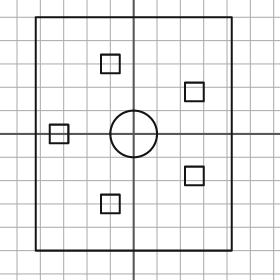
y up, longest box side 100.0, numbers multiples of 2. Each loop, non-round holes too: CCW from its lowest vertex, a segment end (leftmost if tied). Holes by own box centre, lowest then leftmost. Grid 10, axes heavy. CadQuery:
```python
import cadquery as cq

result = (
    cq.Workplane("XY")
    .moveTo(-42.0, -50.0)
    .lineTo(42.0, -50.0)
    .lineTo(42.0, 50.0)
    .lineTo(-42.0, 50.0)
    .close()
    .moveTo(-14.0, -34.0)
    .lineTo(-6.0, -34.0)
    .lineTo(-6.0, -26.0)
    .lineTo(-14.0, -26.0)
    .close()
    .moveTo(22.0, -22.0)
    .lineTo(30.0, -22.0)
    .lineTo(30.0, -14.0)
    .lineTo(22.0, -14.0)
    .close()
    .moveTo(-36.0, -4.0)
    .lineTo(-28.0, -4.0)
    .lineTo(-28.0, 4.0)
    .lineTo(-36.0, 4.0)
    .close()
    .moveTo(0.0, 0.0)
    .circle(10.0)
    .moveTo(22.0, 14.0)
    .lineTo(30.0, 14.0)
    .lineTo(30.0, 22.0)
    .lineTo(22.0, 22.0)
    .close()
    .moveTo(-14.0, 26.0)
    .lineTo(-6.0, 26.0)
    .lineTo(-6.0, 34.0)
    .lineTo(-14.0, 34.0)
    .close()
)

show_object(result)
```